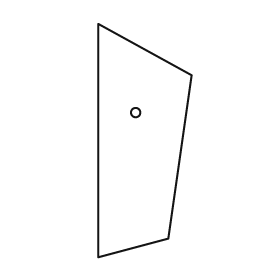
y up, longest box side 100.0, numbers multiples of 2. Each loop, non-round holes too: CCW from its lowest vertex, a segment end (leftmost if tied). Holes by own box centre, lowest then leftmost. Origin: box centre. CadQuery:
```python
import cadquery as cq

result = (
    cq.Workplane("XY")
    .moveTo(-20.0, -50.0)
    .lineTo(10.0, -42.0)
    .lineTo(20.0, 28.0)
    .lineTo(-20.0, 50.0)
    .close()
    .moveTo(-4.0, 12.0)
    .circle(2.0)
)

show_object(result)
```